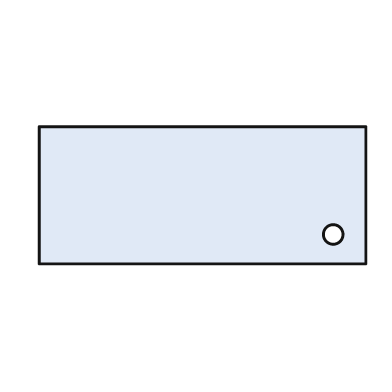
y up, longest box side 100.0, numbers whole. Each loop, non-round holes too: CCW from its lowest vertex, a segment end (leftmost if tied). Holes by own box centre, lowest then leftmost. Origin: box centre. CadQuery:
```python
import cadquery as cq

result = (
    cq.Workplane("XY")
    .moveTo(-50.0, -21.0)
    .lineTo(50.0, -21.0)
    .lineTo(50.0, 21.0)
    .lineTo(-50.0, 21.0)
    .close()
    .moveTo(40.0, -12.0)
    .circle(3.0)
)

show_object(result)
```